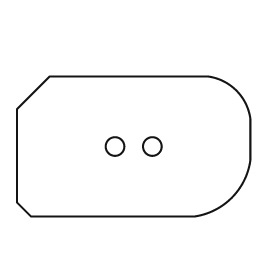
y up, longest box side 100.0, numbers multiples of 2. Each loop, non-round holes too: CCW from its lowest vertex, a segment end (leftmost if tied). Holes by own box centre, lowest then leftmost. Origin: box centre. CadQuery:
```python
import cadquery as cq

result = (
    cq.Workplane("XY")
    .moveTo(-44.0, -30.0)
    .lineTo(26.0, -30.0)
    .threePointArc((42.0, -22.0), (50.0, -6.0))
    .lineTo(50.0, 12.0)
    .threePointArc((44.0, 24.0), (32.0, 30.0))
    .lineTo(-36.0, 30.0)
    .lineTo(-50.0, 16.0)
    .lineTo(-50.0, -24.0)
    .close()
    .moveTo(-8.0, 0.0)
    .circle(4.0)
    .moveTo(8.0, 0.0)
    .circle(4.0)
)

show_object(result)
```